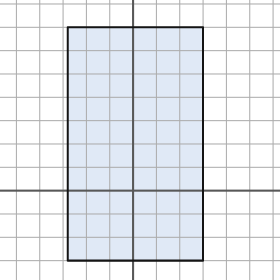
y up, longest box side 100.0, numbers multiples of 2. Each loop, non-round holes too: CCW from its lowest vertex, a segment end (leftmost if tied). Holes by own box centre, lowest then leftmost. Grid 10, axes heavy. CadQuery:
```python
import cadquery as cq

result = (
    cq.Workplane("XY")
    .moveTo(-28.0, -30.0)
    .lineTo(30.0, -30.0)
    .lineTo(30.0, 70.0)
    .lineTo(-28.0, 70.0)
    .close()
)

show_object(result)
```